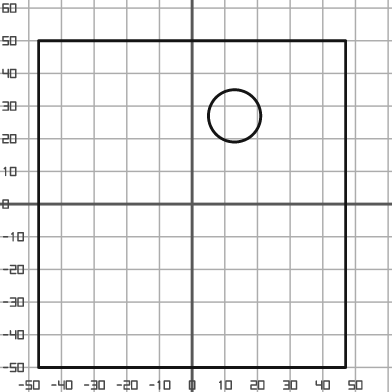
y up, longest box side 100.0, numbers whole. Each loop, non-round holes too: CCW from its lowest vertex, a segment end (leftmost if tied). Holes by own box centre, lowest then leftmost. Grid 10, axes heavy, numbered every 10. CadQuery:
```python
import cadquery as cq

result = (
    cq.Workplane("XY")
    .moveTo(-47.0, -50.0)
    .lineTo(47.0, -50.0)
    .lineTo(47.0, 50.0)
    .lineTo(-47.0, 50.0)
    .close()
    .moveTo(13.0, 27.0)
    .circle(8.0)
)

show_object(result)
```